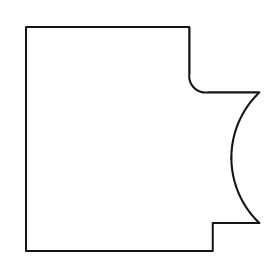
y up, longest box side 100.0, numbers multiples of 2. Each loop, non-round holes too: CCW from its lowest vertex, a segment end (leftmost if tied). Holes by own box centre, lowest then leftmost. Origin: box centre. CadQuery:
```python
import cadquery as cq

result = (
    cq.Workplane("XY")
    .moveTo(-50.0, -48.0)
    .lineTo(30.0, -48.0)
    .lineTo(30.0, -36.0)
    .lineTo(50.0, -36.0)
    .threePointArc((38.0, -8.0), (50.0, 20.0))
    .lineTo(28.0, 20.0)
    .threePointArc((22.0, 22.0), (20.0, 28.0))
    .lineTo(20.0, 48.0)
    .lineTo(-50.0, 48.0)
    .close()
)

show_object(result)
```